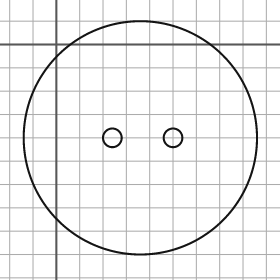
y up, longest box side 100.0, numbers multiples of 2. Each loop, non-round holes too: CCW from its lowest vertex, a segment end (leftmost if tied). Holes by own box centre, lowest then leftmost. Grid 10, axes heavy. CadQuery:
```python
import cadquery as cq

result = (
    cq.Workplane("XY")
    .moveTo(36.0, -40.0)
    .circle(50.0)
    .moveTo(24.0, -40.0)
    .circle(4.0)
    .moveTo(50.0, -40.0)
    .circle(4.0)
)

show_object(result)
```